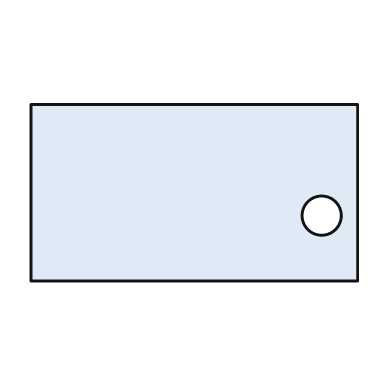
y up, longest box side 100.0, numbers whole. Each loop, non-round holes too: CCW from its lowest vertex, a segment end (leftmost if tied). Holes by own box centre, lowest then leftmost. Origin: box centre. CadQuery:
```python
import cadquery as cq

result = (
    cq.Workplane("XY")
    .moveTo(-50.0, -27.0)
    .lineTo(50.0, -27.0)
    .lineTo(50.0, 27.0)
    .lineTo(-50.0, 27.0)
    .close()
    .moveTo(39.0, -7.0)
    .circle(6.0)
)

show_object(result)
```